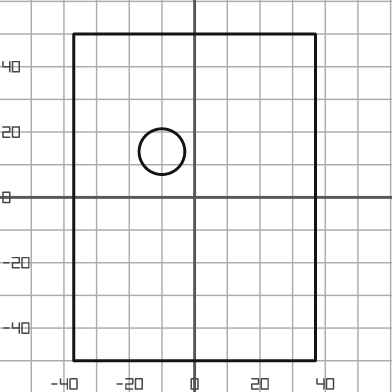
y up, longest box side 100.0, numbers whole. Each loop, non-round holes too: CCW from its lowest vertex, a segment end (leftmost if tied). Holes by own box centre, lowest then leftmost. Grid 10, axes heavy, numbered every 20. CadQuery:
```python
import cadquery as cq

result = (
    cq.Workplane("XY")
    .moveTo(-37.0, -50.0)
    .lineTo(37.0, -50.0)
    .lineTo(37.0, 50.0)
    .lineTo(-37.0, 50.0)
    .close()
    .moveTo(-10.0, 14.0)
    .circle(7.0)
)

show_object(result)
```